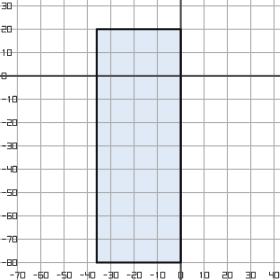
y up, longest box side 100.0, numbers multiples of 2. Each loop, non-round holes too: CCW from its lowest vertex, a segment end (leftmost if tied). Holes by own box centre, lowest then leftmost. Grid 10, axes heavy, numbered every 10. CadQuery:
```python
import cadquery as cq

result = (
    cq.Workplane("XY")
    .moveTo(-36.0, -80.0)
    .lineTo(0.0, -80.0)
    .lineTo(0.0, 20.0)
    .lineTo(-36.0, 20.0)
    .close()
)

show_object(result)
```